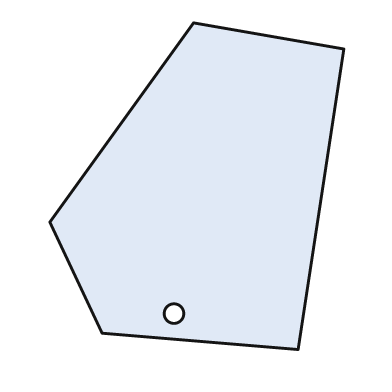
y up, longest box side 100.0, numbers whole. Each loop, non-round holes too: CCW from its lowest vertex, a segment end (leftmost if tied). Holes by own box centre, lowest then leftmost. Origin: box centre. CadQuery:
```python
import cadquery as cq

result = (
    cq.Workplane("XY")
    .moveTo(31.0, -50.0)
    .lineTo(45.0, 42.0)
    .lineTo(-1.0, 50.0)
    .lineTo(-45.0, -11.0)
    .lineTo(-29.0, -45.0)
    .close()
    .moveTo(-7.0, -39.0)
    .circle(3.0)
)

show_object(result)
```